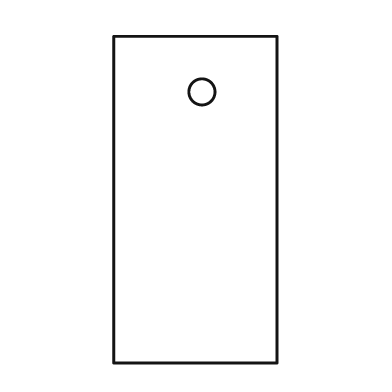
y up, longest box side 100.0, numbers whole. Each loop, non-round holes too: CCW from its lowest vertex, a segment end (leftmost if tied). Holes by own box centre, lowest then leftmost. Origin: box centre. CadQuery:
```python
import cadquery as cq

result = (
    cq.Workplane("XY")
    .moveTo(-25.0, -50.0)
    .lineTo(25.0, -50.0)
    .lineTo(25.0, 50.0)
    .lineTo(-25.0, 50.0)
    .close()
    .moveTo(2.0, 33.0)
    .circle(4.0)
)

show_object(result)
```